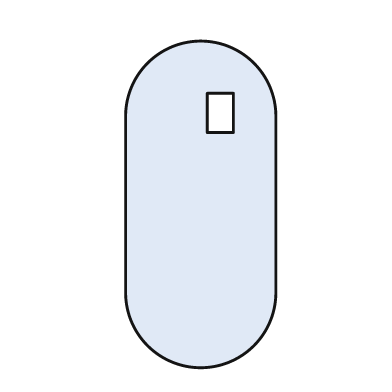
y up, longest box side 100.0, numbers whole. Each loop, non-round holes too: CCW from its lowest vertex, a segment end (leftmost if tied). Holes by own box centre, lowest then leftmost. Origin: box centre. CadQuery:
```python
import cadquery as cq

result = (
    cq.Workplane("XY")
    .moveTo(-23.0, -27.0)
    .threePointArc((0.0, -50.0), (23.0, -27.0))
    .lineTo(23.0, 27.0)
    .threePointArc((0.0, 50.0), (-23.0, 27.0))
    .close()
    .moveTo(2.0, 22.0)
    .lineTo(10.0, 22.0)
    .lineTo(10.0, 34.0)
    .lineTo(2.0, 34.0)
    .close()
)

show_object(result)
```